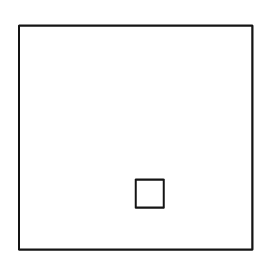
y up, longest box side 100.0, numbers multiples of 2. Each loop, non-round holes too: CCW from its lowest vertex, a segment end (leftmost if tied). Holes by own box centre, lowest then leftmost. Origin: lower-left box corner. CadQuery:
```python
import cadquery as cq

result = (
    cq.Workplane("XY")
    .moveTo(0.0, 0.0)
    .lineTo(100.0, 0.0)
    .lineTo(100.0, 96.0)
    .lineTo(0.0, 96.0)
    .close()
    .moveTo(50.0, 18.0)
    .lineTo(62.0, 18.0)
    .lineTo(62.0, 30.0)
    .lineTo(50.0, 30.0)
    .close()
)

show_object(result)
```